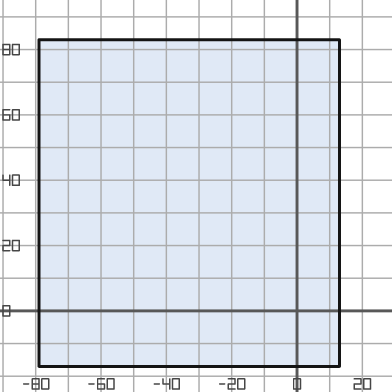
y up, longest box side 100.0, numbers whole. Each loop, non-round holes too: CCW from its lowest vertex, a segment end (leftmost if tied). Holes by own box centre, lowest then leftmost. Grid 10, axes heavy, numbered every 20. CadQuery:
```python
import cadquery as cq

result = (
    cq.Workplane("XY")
    .moveTo(-79.0, -17.0)
    .lineTo(13.0, -17.0)
    .lineTo(13.0, 83.0)
    .lineTo(-79.0, 83.0)
    .close()
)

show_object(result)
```